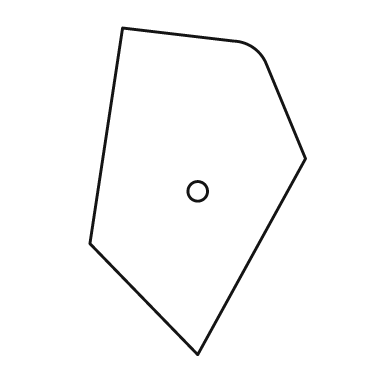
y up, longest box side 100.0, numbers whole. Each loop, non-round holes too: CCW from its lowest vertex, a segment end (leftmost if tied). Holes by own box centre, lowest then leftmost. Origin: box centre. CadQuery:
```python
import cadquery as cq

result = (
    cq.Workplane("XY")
    .moveTo(0.0, -50.0)
    .lineTo(33.0, 10.0)
    .lineTo(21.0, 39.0)
    .threePointArc((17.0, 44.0), (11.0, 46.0))
    .lineTo(-23.0, 50.0)
    .lineTo(-33.0, -16.0)
    .close()
    .moveTo(0.0, 0.0)
    .circle(3.0)
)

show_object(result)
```